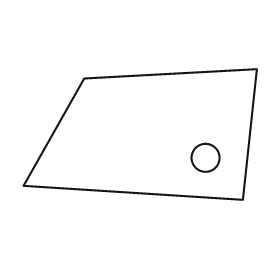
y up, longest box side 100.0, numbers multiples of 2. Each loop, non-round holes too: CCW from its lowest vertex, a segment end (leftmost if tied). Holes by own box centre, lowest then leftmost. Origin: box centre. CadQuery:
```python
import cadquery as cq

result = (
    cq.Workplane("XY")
    .moveTo(44.0, -28.0)
    .lineTo(50.0, 28.0)
    .lineTo(-24.0, 24.0)
    .lineTo(-50.0, -22.0)
    .close()
    .moveTo(28.0, -10.0)
    .circle(6.0)
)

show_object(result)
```